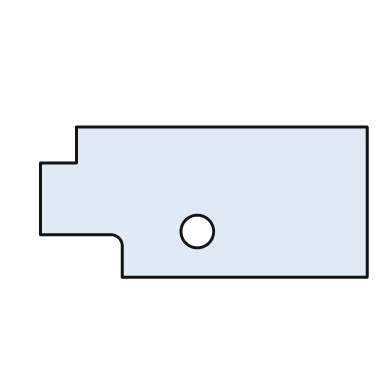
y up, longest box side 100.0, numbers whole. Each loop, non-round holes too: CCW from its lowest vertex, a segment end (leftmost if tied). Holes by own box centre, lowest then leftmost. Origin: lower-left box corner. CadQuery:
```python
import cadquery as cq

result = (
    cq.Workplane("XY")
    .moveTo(25.0, 0.0)
    .lineTo(100.0, 0.0)
    .lineTo(100.0, 46.0)
    .lineTo(11.0, 46.0)
    .lineTo(11.0, 35.0)
    .lineTo(0.0, 35.0)
    .lineTo(0.0, 13.0)
    .lineTo(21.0, 13.0)
    .threePointArc((24.0, 12.0), (25.0, 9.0))
    .close()
    .moveTo(48.0, 14.0)
    .circle(5.0)
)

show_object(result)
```